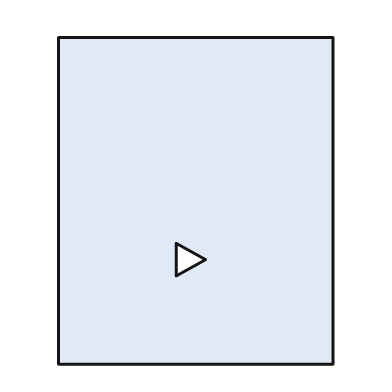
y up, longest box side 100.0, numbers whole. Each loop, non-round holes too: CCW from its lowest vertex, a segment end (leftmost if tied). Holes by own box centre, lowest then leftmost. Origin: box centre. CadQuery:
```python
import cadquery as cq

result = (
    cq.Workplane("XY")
    .moveTo(-42.0, -50.0)
    .lineTo(42.0, -50.0)
    .lineTo(42.0, 50.0)
    .lineTo(-42.0, 50.0)
    .close()
    .moveTo(-6.0, -23.0)
    .lineTo(3.0, -18.0)
    .lineTo(-6.0, -13.0)
    .close()
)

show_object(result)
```